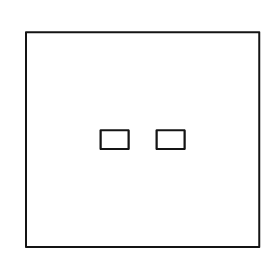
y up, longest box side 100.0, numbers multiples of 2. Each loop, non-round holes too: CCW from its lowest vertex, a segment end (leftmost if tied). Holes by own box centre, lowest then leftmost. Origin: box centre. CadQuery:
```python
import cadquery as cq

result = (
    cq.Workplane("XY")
    .moveTo(-50.0, -46.0)
    .lineTo(50.0, -46.0)
    .lineTo(50.0, 46.0)
    .lineTo(-50.0, 46.0)
    .close()
    .moveTo(-18.0, -4.0)
    .lineTo(-6.0, -4.0)
    .lineTo(-6.0, 4.0)
    .lineTo(-18.0, 4.0)
    .close()
    .moveTo(6.0, -4.0)
    .lineTo(18.0, -4.0)
    .lineTo(18.0, 4.0)
    .lineTo(6.0, 4.0)
    .close()
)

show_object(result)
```